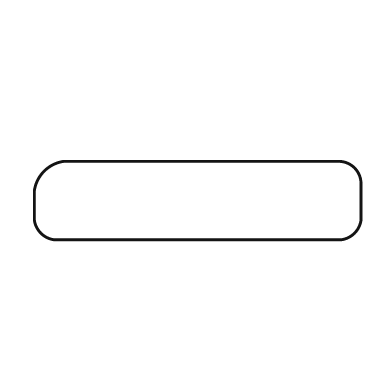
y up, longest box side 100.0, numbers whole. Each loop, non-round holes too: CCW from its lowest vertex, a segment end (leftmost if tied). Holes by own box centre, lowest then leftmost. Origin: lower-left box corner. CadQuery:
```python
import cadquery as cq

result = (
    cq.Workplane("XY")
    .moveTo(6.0, 0.0)
    .lineTo(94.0, 0.0)
    .threePointArc((98.0, 2.0), (100.0, 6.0))
    .lineTo(100.0, 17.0)
    .threePointArc((98.0, 22.0), (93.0, 24.0))
    .lineTo(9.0, 24.0)
    .threePointArc((3.0, 21.0), (0.0, 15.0))
    .lineTo(0.0, 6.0)
    .threePointArc((2.0, 2.0), (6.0, 0.0))
    .close()
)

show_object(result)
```